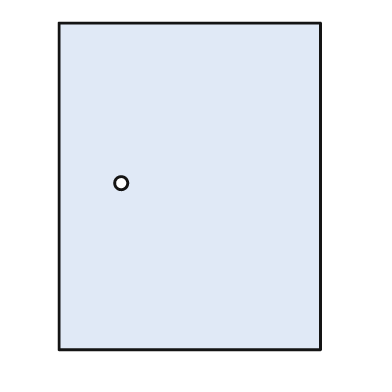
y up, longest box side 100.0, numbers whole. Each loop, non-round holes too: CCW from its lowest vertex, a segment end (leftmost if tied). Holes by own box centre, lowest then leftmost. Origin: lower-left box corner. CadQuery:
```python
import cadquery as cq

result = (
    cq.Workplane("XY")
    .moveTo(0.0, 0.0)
    .lineTo(80.0, 0.0)
    .lineTo(80.0, 100.0)
    .lineTo(0.0, 100.0)
    .close()
    .moveTo(19.0, 51.0)
    .circle(2.0)
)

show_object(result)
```